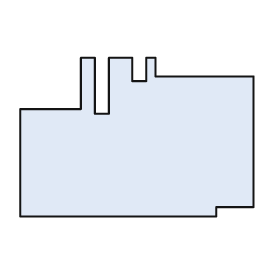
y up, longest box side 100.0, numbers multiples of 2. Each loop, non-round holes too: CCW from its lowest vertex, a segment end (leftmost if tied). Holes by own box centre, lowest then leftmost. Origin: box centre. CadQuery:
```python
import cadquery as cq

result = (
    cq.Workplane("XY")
    .moveTo(-50.0, -34.0)
    .lineTo(34.0, -34.0)
    .lineTo(34.0, -30.0)
    .lineTo(50.0, -30.0)
    .lineTo(50.0, 26.0)
    .lineTo(8.0, 26.0)
    .lineTo(8.0, 34.0)
    .lineTo(4.0, 34.0)
    .lineTo(4.0, 24.0)
    .lineTo(-2.0, 24.0)
    .lineTo(-2.0, 34.0)
    .lineTo(-12.0, 34.0)
    .lineTo(-12.0, 10.0)
    .lineTo(-18.0, 10.0)
    .lineTo(-18.0, 34.0)
    .lineTo(-24.0, 34.0)
    .lineTo(-24.0, 12.0)
    .lineTo(-50.0, 12.0)
    .close()
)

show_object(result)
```